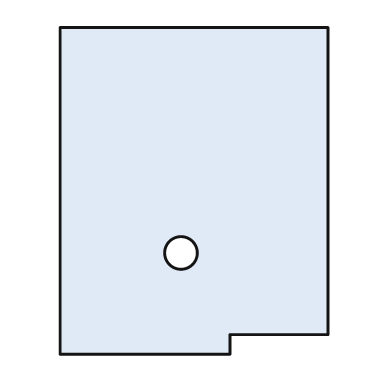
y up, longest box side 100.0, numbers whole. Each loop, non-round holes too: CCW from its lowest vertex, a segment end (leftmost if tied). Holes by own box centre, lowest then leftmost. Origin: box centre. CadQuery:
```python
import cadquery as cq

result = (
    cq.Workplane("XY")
    .moveTo(-41.0, -50.0)
    .lineTo(11.0, -50.0)
    .lineTo(11.0, -44.0)
    .lineTo(41.0, -44.0)
    .lineTo(41.0, 50.0)
    .lineTo(-41.0, 50.0)
    .close()
    .moveTo(-4.0, -19.0)
    .circle(5.0)
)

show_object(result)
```